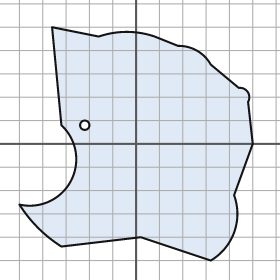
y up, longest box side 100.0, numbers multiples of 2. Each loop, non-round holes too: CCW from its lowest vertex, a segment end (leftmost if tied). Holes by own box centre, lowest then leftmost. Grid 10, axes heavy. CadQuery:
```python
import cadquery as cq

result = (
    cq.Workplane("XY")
    .moveTo(32.0, -50.0)
    .threePointArc((42.0, -38.0), (42.0, -22.0))
    .lineTo(50.0, 0.0)
    .lineTo(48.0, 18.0)
    .threePointArc((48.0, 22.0), (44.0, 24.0))
    .lineTo(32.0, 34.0)
    .threePointArc((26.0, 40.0), (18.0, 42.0))
    .lineTo(8.0, 46.0)
    .threePointArc((-4.0, 48.0), (-16.0, 46.0))
    .lineTo(-36.0, 50.0)
    .lineTo(-32.0, 8.0)
    .threePointArc((-28.0, -16.0), (-50.0, -26.0))
    .threePointArc((-42.0, -36.0), (-32.0, -44.0))
    .lineTo(2.0, -40.0)
    .close()
    .moveTo(-22.0, 8.0)
    .circle(2.0)
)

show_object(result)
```